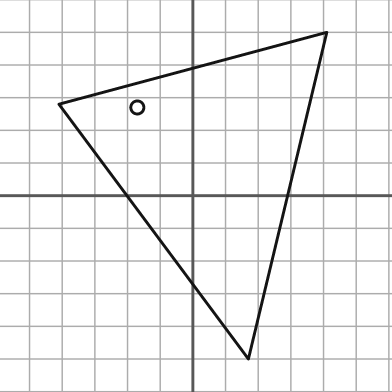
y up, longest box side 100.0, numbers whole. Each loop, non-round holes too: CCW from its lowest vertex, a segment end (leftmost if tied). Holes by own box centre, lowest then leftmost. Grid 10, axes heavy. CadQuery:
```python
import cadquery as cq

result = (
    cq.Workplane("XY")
    .moveTo(17.0, -50.0)
    .lineTo(41.0, 50.0)
    .lineTo(-41.0, 28.0)
    .close()
    .moveTo(-17.0, 27.0)
    .circle(2.0)
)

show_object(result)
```